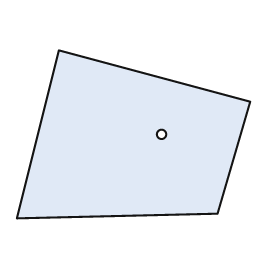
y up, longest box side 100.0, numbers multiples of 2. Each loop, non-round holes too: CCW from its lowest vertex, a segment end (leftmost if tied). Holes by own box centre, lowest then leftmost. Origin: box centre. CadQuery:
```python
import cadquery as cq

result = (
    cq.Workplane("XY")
    .moveTo(-50.0, -36.0)
    .lineTo(36.0, -34.0)
    .lineTo(50.0, 14.0)
    .lineTo(-32.0, 36.0)
    .close()
    .moveTo(12.0, 0.0)
    .circle(2.0)
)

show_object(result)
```